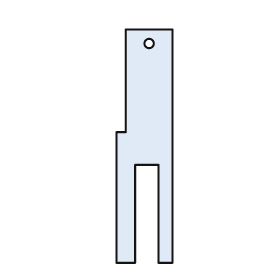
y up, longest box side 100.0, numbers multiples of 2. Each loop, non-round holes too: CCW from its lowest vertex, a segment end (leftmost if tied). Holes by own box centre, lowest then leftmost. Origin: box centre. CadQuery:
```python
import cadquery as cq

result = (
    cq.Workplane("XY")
    .moveTo(-12.0, -50.0)
    .lineTo(-4.0, -50.0)
    .lineTo(-4.0, -8.0)
    .lineTo(6.0, -8.0)
    .lineTo(6.0, -50.0)
    .lineTo(12.0, -50.0)
    .lineTo(12.0, 50.0)
    .lineTo(-8.0, 50.0)
    .lineTo(-8.0, 6.0)
    .lineTo(-12.0, 6.0)
    .close()
    .moveTo(2.0, 44.0)
    .circle(2.0)
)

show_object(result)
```